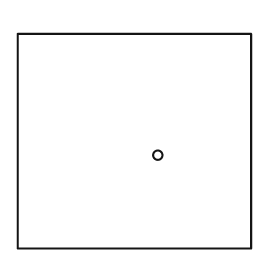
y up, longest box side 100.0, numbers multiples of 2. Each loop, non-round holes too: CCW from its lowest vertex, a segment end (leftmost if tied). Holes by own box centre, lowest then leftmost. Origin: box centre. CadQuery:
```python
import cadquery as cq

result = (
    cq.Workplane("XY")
    .moveTo(-50.0, -46.0)
    .lineTo(50.0, -46.0)
    .lineTo(50.0, 46.0)
    .lineTo(-50.0, 46.0)
    .close()
    .moveTo(10.0, -6.0)
    .circle(2.0)
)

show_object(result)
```